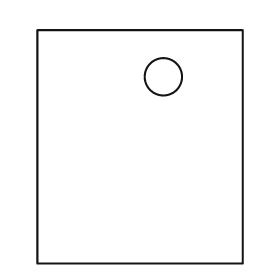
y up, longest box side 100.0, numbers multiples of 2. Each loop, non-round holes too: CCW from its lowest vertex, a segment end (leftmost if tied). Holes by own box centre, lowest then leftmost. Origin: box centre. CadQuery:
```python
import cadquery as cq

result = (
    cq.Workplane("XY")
    .moveTo(-44.0, -50.0)
    .lineTo(44.0, -50.0)
    .lineTo(44.0, 50.0)
    .lineTo(-44.0, 50.0)
    .close()
    .moveTo(10.0, 30.0)
    .circle(8.0)
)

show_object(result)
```